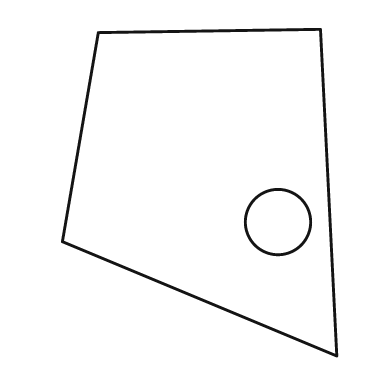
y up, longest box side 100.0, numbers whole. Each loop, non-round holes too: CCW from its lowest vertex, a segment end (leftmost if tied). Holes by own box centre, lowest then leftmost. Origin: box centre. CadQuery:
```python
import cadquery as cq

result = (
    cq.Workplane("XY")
    .moveTo(42.0, -50.0)
    .lineTo(37.0, 50.0)
    .lineTo(-31.0, 49.0)
    .lineTo(-42.0, -15.0)
    .close()
    .moveTo(24.0, -9.0)
    .circle(10.0)
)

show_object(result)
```